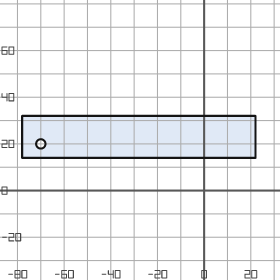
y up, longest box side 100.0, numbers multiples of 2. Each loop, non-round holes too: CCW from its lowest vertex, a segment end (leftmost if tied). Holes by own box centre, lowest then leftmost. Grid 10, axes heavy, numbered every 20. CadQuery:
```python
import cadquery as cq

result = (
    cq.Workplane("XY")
    .moveTo(-78.0, 14.0)
    .lineTo(22.0, 14.0)
    .lineTo(22.0, 32.0)
    .lineTo(-78.0, 32.0)
    .close()
    .moveTo(-70.0, 20.0)
    .circle(2.0)
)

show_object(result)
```